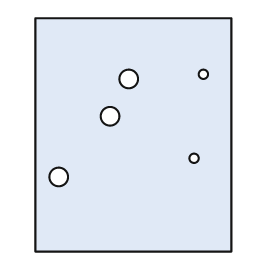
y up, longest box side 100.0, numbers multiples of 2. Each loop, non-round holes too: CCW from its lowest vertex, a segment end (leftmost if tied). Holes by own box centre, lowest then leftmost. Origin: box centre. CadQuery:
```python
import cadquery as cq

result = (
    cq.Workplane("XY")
    .moveTo(-42.0, -50.0)
    .lineTo(42.0, -50.0)
    .lineTo(42.0, 50.0)
    .lineTo(-42.0, 50.0)
    .close()
    .moveTo(-32.0, -18.0)
    .circle(4.0)
    .moveTo(26.0, -10.0)
    .circle(2.0)
    .moveTo(-10.0, 8.0)
    .circle(4.0)
    .moveTo(-2.0, 24.0)
    .circle(4.0)
    .moveTo(30.0, 26.0)
    .circle(2.0)
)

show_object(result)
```